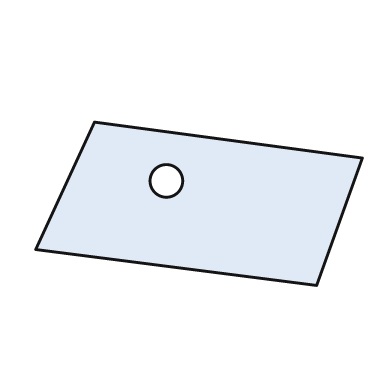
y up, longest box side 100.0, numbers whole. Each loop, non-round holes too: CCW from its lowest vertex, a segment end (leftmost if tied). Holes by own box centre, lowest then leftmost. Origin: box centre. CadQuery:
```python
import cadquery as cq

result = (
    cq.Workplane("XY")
    .moveTo(36.0, -25.0)
    .lineTo(50.0, 14.0)
    .lineTo(-32.0, 25.0)
    .lineTo(-50.0, -14.0)
    .close()
    .moveTo(-10.0, 7.0)
    .circle(5.0)
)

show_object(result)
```